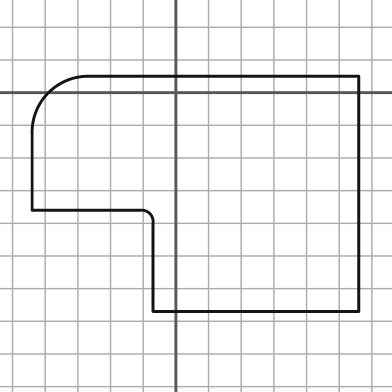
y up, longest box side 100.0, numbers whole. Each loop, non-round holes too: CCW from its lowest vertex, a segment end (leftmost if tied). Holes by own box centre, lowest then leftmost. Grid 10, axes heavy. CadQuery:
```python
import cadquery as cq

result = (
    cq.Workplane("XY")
    .moveTo(-7.0, -67.0)
    .lineTo(56.0, -67.0)
    .lineTo(56.0, 5.0)
    .lineTo(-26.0, 5.0)
    .threePointArc((-39.0, 0.0), (-44.0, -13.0))
    .lineTo(-44.0, -36.0)
    .lineTo(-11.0, -36.0)
    .threePointArc((-8.0, -37.0), (-7.0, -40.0))
    .close()
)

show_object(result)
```